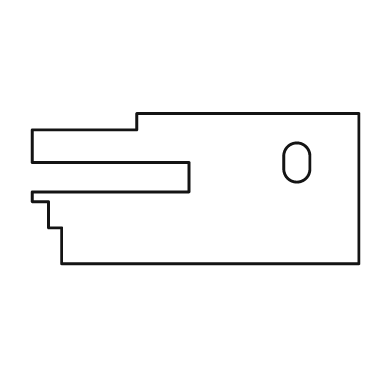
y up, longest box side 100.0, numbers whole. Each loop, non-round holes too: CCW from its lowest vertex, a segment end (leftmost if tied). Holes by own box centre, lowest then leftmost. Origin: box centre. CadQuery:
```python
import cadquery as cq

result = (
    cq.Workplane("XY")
    .moveTo(-41.0, -23.0)
    .lineTo(50.0, -23.0)
    .lineTo(50.0, 23.0)
    .lineTo(-18.0, 23.0)
    .lineTo(-18.0, 18.0)
    .lineTo(-50.0, 18.0)
    .lineTo(-50.0, 8.0)
    .lineTo(-2.0, 8.0)
    .lineTo(-2.0, -1.0)
    .lineTo(-50.0, -1.0)
    .lineTo(-50.0, -4.0)
    .lineTo(-45.0, -4.0)
    .lineTo(-45.0, -12.0)
    .lineTo(-41.0, -12.0)
    .close()
    .moveTo(27.0, 6.0)
    .threePointArc((31.0, 2.0), (35.0, 6.0))
    .lineTo(35.0, 10.0)
    .threePointArc((31.0, 14.0), (27.0, 10.0))
    .close()
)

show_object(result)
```